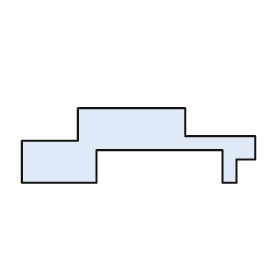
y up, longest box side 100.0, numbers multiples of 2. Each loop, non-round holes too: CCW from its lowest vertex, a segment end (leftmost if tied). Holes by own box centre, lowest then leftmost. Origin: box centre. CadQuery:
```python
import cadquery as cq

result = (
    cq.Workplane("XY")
    .moveTo(-50.0, -16.0)
    .lineTo(-18.0, -16.0)
    .lineTo(-18.0, -2.0)
    .lineTo(36.0, -2.0)
    .lineTo(36.0, -16.0)
    .lineTo(42.0, -16.0)
    .lineTo(42.0, -6.0)
    .lineTo(50.0, -6.0)
    .lineTo(50.0, 4.0)
    .lineTo(20.0, 4.0)
    .lineTo(20.0, 16.0)
    .lineTo(-26.0, 16.0)
    .lineTo(-26.0, 2.0)
    .lineTo(-50.0, 2.0)
    .close()
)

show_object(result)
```